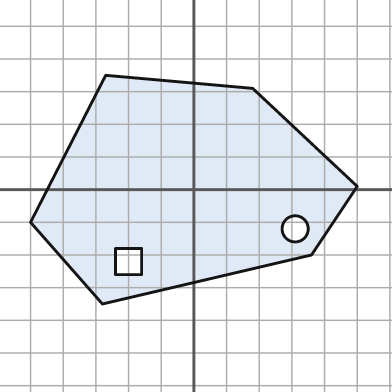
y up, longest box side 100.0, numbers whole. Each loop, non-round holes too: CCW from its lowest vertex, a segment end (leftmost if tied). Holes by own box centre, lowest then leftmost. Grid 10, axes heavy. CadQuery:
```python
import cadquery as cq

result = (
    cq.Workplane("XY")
    .moveTo(-28.0, -35.0)
    .lineTo(36.0, -20.0)
    .lineTo(50.0, 1.0)
    .lineTo(18.0, 31.0)
    .lineTo(-27.0, 35.0)
    .lineTo(-50.0, -10.0)
    .close()
    .moveTo(-24.0, -26.0)
    .lineTo(-16.0, -26.0)
    .lineTo(-16.0, -18.0)
    .lineTo(-24.0, -18.0)
    .close()
    .moveTo(31.0, -12.0)
    .circle(4.0)
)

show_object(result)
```